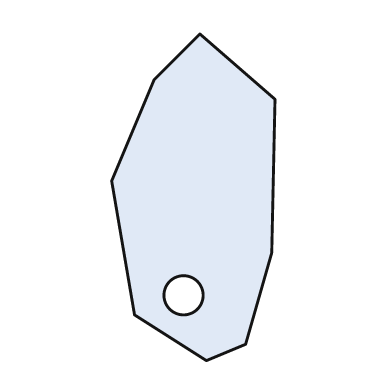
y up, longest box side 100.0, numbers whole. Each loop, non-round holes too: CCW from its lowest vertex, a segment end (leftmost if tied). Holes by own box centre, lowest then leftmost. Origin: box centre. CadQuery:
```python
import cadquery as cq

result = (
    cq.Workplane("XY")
    .moveTo(4.0, -50.0)
    .lineTo(16.0, -45.0)
    .lineTo(24.0, -17.0)
    .lineTo(25.0, 30.0)
    .lineTo(2.0, 50.0)
    .lineTo(-12.0, 36.0)
    .lineTo(-25.0, 5.0)
    .lineTo(-18.0, -36.0)
    .close()
    .moveTo(-3.0, -30.0)
    .circle(6.0)
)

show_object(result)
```